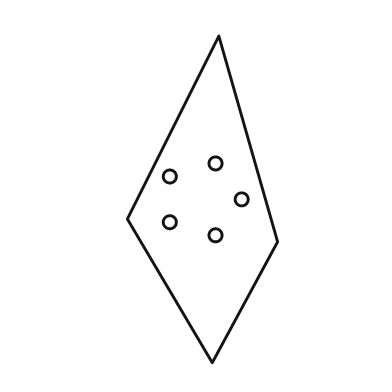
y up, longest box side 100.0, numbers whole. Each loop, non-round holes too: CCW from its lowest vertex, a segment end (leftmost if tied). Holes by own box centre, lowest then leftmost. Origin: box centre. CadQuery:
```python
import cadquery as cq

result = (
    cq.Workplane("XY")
    .moveTo(3.0, -50.0)
    .lineTo(23.0, -13.0)
    .lineTo(5.0, 50.0)
    .lineTo(-23.0, -6.0)
    .close()
    .moveTo(4.0, -11.0)
    .circle(2.0)
    .moveTo(-10.0, -7.0)
    .circle(2.0)
    .moveTo(12.0, 0.0)
    .circle(2.0)
    .moveTo(-10.0, 7.0)
    .circle(2.0)
    .moveTo(4.0, 11.0)
    .circle(2.0)
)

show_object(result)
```